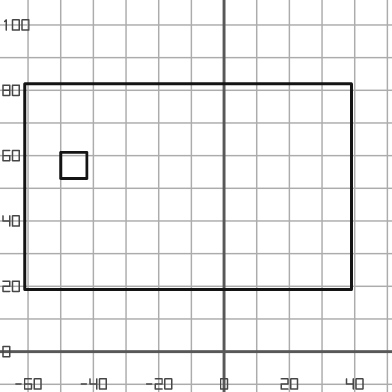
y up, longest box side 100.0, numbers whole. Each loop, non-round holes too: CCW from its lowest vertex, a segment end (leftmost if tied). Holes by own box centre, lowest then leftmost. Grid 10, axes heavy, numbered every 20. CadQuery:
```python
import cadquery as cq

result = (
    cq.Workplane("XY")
    .moveTo(-61.0, 19.0)
    .lineTo(39.0, 19.0)
    .lineTo(39.0, 82.0)
    .lineTo(-61.0, 82.0)
    .close()
    .moveTo(-50.0, 53.0)
    .lineTo(-42.0, 53.0)
    .lineTo(-42.0, 61.0)
    .lineTo(-50.0, 61.0)
    .close()
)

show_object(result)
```